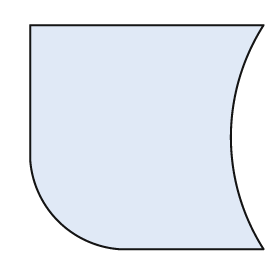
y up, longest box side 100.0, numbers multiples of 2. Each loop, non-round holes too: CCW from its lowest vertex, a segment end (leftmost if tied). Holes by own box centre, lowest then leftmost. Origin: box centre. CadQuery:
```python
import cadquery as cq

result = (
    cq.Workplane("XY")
    .moveTo(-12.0, -48.0)
    .lineTo(50.0, -48.0)
    .threePointArc((36.0, 0.0), (50.0, 48.0))
    .lineTo(-50.0, 48.0)
    .lineTo(-50.0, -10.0)
    .threePointArc((-38.0, -36.0), (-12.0, -48.0))
    .close()
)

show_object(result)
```